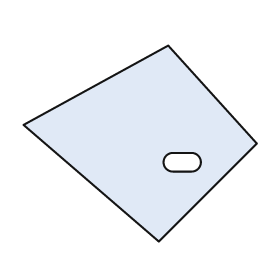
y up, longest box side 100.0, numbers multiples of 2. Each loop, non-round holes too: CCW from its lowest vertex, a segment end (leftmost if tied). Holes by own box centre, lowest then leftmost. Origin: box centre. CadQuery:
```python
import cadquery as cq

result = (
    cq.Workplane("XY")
    .moveTo(8.0, -42.0)
    .lineTo(50.0, 0.0)
    .lineTo(12.0, 42.0)
    .lineTo(-50.0, 8.0)
    .close()
    .moveTo(14.0, -12.0)
    .lineTo(22.0, -12.0)
    .threePointArc((26.0, -8.0), (22.0, -4.0))
    .lineTo(14.0, -4.0)
    .threePointArc((10.0, -8.0), (14.0, -12.0))
    .close()
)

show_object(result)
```